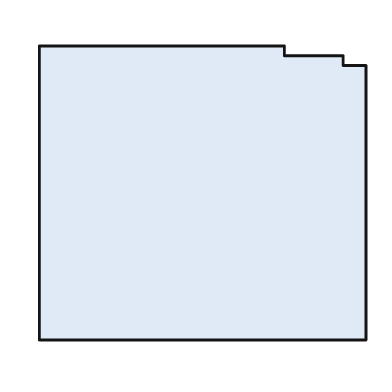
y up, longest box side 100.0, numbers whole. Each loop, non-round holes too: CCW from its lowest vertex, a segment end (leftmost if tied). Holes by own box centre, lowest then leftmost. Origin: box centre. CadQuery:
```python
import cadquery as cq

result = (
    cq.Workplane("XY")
    .moveTo(-50.0, -45.0)
    .lineTo(50.0, -45.0)
    .lineTo(50.0, 39.0)
    .lineTo(43.0, 39.0)
    .lineTo(43.0, 42.0)
    .lineTo(25.0, 42.0)
    .lineTo(25.0, 45.0)
    .lineTo(-50.0, 45.0)
    .close()
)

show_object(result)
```